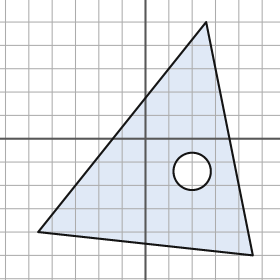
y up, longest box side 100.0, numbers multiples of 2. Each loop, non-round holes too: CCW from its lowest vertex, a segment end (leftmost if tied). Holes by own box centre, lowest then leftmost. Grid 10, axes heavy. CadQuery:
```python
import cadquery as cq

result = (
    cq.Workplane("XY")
    .moveTo(46.0, -50.0)
    .lineTo(26.0, 50.0)
    .lineTo(-46.0, -40.0)
    .close()
    .moveTo(20.0, -14.0)
    .circle(8.0)
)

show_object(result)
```